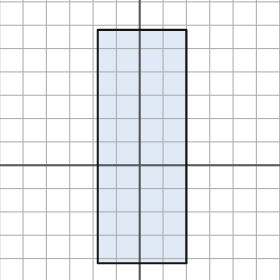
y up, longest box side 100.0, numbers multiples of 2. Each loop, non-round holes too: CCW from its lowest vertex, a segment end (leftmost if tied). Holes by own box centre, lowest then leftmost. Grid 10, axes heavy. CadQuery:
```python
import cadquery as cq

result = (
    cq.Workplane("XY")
    .moveTo(-18.0, -42.0)
    .lineTo(20.0, -42.0)
    .lineTo(20.0, 58.0)
    .lineTo(-18.0, 58.0)
    .close()
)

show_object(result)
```